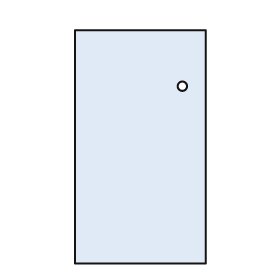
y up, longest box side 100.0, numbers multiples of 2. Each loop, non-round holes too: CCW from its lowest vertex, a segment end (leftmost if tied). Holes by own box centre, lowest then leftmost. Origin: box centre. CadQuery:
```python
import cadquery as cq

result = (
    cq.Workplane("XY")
    .moveTo(-28.0, -50.0)
    .lineTo(28.0, -50.0)
    .lineTo(28.0, 50.0)
    .lineTo(-28.0, 50.0)
    .close()
    .moveTo(18.0, 26.0)
    .circle(2.0)
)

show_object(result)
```